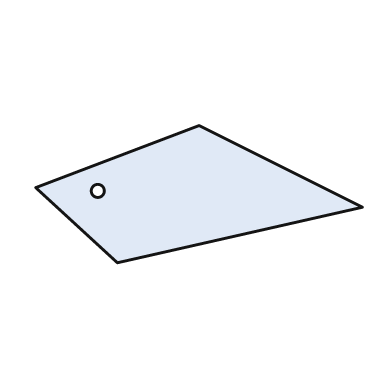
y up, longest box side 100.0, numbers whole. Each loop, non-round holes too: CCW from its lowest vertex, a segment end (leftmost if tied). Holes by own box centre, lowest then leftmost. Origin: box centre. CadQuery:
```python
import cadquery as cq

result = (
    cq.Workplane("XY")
    .moveTo(-25.0, -21.0)
    .lineTo(50.0, -4.0)
    .lineTo(0.0, 21.0)
    .lineTo(-50.0, 2.0)
    .close()
    .moveTo(-31.0, 1.0)
    .circle(2.0)
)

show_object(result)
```